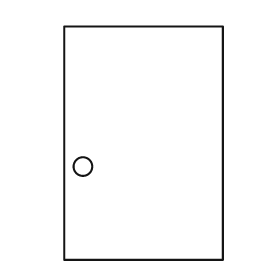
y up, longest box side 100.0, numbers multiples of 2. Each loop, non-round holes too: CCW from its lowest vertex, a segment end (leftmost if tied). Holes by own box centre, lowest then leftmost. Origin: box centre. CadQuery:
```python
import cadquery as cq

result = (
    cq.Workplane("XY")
    .moveTo(-34.0, -50.0)
    .lineTo(34.0, -50.0)
    .lineTo(34.0, 50.0)
    .lineTo(-34.0, 50.0)
    .close()
    .moveTo(-26.0, -10.0)
    .circle(4.0)
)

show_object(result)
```